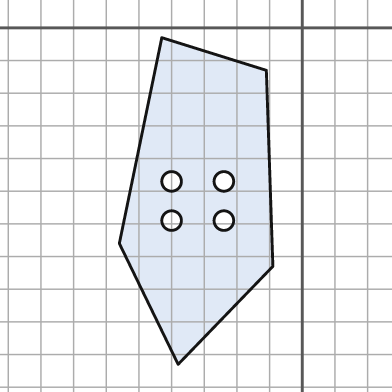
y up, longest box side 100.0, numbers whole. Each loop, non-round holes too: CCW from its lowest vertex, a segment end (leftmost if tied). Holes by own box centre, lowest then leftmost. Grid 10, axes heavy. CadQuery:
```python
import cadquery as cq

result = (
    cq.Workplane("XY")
    .moveTo(-38.0, -103.0)
    .lineTo(-9.0, -73.0)
    .lineTo(-11.0, -13.0)
    .lineTo(-43.0, -3.0)
    .lineTo(-56.0, -66.0)
    .close()
    .moveTo(-40.0, -59.0)
    .circle(3.0)
    .moveTo(-24.0, -59.0)
    .circle(3.0)
    .moveTo(-40.0, -47.0)
    .circle(3.0)
    .moveTo(-24.0, -47.0)
    .circle(3.0)
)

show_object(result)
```